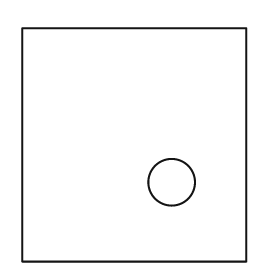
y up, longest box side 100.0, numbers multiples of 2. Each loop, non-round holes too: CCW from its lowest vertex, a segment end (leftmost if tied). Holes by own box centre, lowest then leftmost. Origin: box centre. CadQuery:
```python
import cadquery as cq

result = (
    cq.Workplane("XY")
    .moveTo(-48.0, -50.0)
    .lineTo(48.0, -50.0)
    .lineTo(48.0, 50.0)
    .lineTo(-48.0, 50.0)
    .close()
    .moveTo(16.0, -16.0)
    .circle(10.0)
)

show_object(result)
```